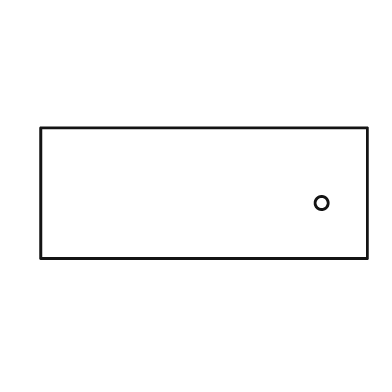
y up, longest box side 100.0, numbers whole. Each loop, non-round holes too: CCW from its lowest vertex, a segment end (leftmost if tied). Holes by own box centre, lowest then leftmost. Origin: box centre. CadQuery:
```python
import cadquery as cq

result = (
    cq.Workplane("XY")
    .moveTo(-50.0, -20.0)
    .lineTo(50.0, -20.0)
    .lineTo(50.0, 20.0)
    .lineTo(-50.0, 20.0)
    .close()
    .moveTo(36.0, -3.0)
    .circle(2.0)
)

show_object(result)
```